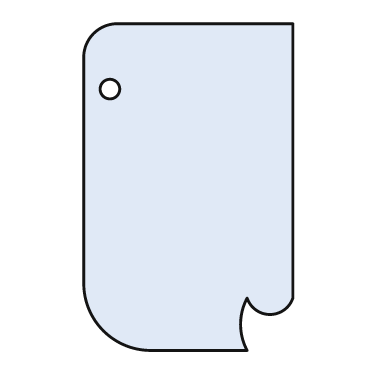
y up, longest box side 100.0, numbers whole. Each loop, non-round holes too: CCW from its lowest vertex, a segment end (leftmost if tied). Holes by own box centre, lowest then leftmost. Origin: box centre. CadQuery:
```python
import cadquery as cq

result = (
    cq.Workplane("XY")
    .moveTo(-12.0, -50.0)
    .lineTo(18.0, -50.0)
    .threePointArc((16.0, -42.0), (18.0, -34.0))
    .threePointArc((25.0, -39.0), (32.0, -34.0))
    .lineTo(32.0, 50.0)
    .lineTo(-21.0, 50.0)
    .threePointArc((-29.0, 47.0), (-32.0, 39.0))
    .lineTo(-32.0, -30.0)
    .threePointArc((-26.0, -44.0), (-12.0, -50.0))
    .close()
    .moveTo(-24.0, 30.0)
    .circle(3.0)
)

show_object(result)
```